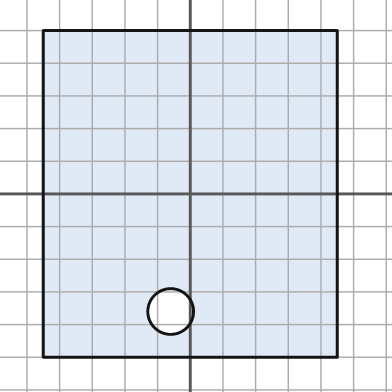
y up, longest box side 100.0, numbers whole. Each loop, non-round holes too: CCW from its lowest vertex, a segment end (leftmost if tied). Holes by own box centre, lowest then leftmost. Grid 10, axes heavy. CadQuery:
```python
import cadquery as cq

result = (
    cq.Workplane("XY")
    .moveTo(-45.0, -50.0)
    .lineTo(45.0, -50.0)
    .lineTo(45.0, 50.0)
    .lineTo(-45.0, 50.0)
    .close()
    .moveTo(-6.0, -36.0)
    .circle(7.0)
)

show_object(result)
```